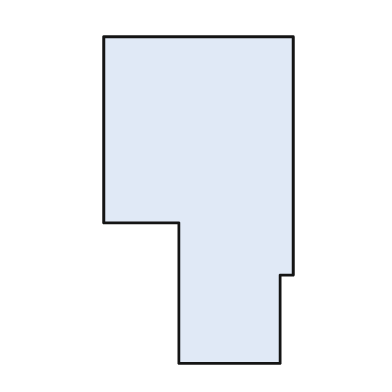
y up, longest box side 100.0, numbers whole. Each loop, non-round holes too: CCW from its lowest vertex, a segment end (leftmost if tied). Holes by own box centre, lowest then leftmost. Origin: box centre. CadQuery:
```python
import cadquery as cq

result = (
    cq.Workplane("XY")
    .moveTo(-6.0, -50.0)
    .lineTo(25.0, -50.0)
    .lineTo(25.0, -23.0)
    .lineTo(29.0, -23.0)
    .lineTo(29.0, 50.0)
    .lineTo(-29.0, 50.0)
    .lineTo(-29.0, -7.0)
    .lineTo(-6.0, -7.0)
    .close()
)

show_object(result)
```